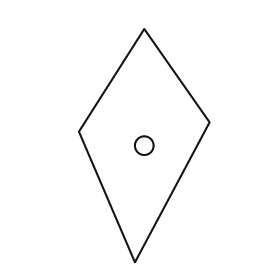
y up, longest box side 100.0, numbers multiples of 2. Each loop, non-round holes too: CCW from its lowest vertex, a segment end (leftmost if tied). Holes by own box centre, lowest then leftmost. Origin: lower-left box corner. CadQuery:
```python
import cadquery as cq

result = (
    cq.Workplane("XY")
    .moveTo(24.0, 0.0)
    .lineTo(56.0, 60.0)
    .lineTo(28.0, 100.0)
    .lineTo(0.0, 56.0)
    .close()
    .moveTo(28.0, 50.0)
    .circle(4.0)
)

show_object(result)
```